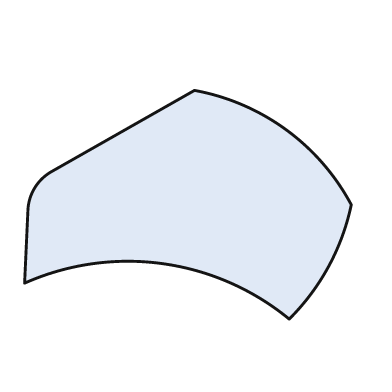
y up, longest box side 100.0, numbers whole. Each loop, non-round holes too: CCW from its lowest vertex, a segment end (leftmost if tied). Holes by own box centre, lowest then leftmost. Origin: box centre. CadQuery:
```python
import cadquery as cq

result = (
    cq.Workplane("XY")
    .moveTo(31.0, -35.0)
    .threePointArc((43.0, -19.0), (50.0, 0.0))
    .threePointArc((30.0, 23.0), (2.0, 35.0))
    .lineTo(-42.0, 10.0)
    .threePointArc((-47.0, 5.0), (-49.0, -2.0))
    .lineTo(-50.0, -24.0)
    .threePointArc((-8.0, -18.0), (31.0, -35.0))
    .close()
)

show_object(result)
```